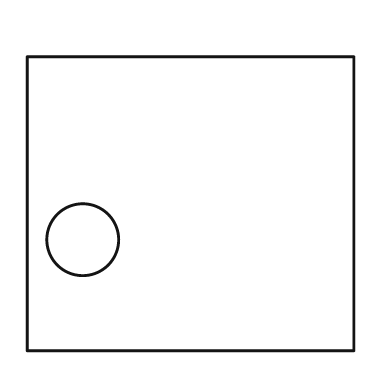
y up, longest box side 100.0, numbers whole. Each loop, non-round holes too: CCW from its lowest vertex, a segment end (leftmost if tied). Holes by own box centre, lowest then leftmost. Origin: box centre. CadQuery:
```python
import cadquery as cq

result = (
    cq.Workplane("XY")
    .moveTo(-50.0, -45.0)
    .lineTo(50.0, -45.0)
    .lineTo(50.0, 45.0)
    .lineTo(-50.0, 45.0)
    .close()
    .moveTo(-33.0, -11.0)
    .circle(11.0)
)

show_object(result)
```